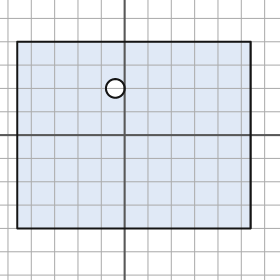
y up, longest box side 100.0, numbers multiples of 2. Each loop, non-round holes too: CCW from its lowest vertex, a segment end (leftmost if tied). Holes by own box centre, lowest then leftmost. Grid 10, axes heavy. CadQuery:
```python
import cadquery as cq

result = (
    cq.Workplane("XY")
    .moveTo(-46.0, -40.0)
    .lineTo(54.0, -40.0)
    .lineTo(54.0, 40.0)
    .lineTo(-46.0, 40.0)
    .close()
    .moveTo(-4.0, 20.0)
    .circle(4.0)
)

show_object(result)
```